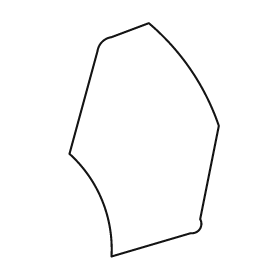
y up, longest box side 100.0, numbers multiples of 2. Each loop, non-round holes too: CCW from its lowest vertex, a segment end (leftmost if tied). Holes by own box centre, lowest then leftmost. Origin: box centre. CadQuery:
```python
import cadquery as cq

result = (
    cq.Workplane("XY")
    .moveTo(-14.0, -50.0)
    .lineTo(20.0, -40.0)
    .threePointArc((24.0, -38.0), (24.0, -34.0))
    .lineTo(32.0, 6.0)
    .threePointArc((20.0, 30.0), (2.0, 50.0))
    .lineTo(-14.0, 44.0)
    .threePointArc((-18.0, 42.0), (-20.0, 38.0))
    .lineTo(-32.0, -6.0)
    .threePointArc((-18.0, -26.0), (-14.0, -50.0))
    .close()
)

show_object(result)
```